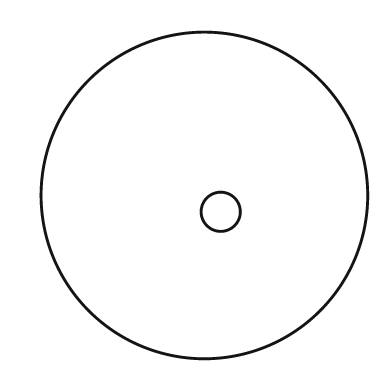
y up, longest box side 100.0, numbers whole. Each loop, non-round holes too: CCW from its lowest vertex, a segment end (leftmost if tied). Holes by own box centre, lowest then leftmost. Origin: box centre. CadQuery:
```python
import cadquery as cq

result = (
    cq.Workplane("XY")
    .moveTo(0.0, 0.0)
    .circle(50.0)
    .moveTo(5.0, -5.0)
    .circle(6.0)
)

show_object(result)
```